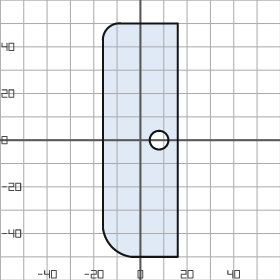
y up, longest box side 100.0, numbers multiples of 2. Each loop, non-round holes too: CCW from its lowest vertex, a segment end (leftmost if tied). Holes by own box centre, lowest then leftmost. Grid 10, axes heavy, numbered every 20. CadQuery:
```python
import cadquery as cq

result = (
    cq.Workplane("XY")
    .moveTo(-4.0, -50.0)
    .lineTo(16.0, -50.0)
    .lineTo(16.0, 50.0)
    .lineTo(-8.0, 50.0)
    .threePointArc((-14.0, 48.0), (-16.0, 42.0))
    .lineTo(-16.0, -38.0)
    .threePointArc((-12.0, -46.0), (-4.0, -50.0))
    .close()
    .moveTo(8.0, 0.0)
    .circle(4.0)
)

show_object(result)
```